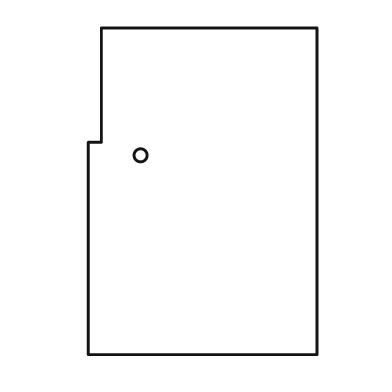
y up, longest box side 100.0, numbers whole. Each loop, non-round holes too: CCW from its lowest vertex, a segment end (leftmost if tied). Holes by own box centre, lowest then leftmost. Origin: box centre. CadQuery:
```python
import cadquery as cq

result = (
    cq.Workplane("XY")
    .moveTo(-35.0, -50.0)
    .lineTo(35.0, -50.0)
    .lineTo(35.0, 50.0)
    .lineTo(-31.0, 50.0)
    .lineTo(-31.0, 15.0)
    .lineTo(-35.0, 15.0)
    .close()
    .moveTo(-19.0, 11.0)
    .circle(2.0)
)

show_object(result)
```